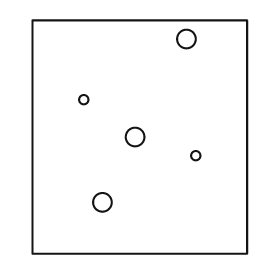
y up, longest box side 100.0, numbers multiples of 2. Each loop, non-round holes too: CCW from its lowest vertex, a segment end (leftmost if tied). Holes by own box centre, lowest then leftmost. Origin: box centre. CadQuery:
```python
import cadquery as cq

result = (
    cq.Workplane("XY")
    .moveTo(-46.0, -50.0)
    .lineTo(46.0, -50.0)
    .lineTo(46.0, 50.0)
    .lineTo(-46.0, 50.0)
    .close()
    .moveTo(-16.0, -28.0)
    .circle(4.0)
    .moveTo(24.0, -8.0)
    .circle(2.0)
    .moveTo(-2.0, 0.0)
    .circle(4.0)
    .moveTo(-24.0, 16.0)
    .circle(2.0)
    .moveTo(20.0, 42.0)
    .circle(4.0)
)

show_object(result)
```